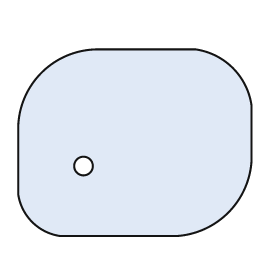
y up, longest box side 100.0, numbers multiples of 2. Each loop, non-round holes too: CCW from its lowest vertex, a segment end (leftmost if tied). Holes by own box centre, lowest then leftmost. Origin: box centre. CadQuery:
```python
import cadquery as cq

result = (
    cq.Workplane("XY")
    .moveTo(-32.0, -40.0)
    .lineTo(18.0, -40.0)
    .threePointArc((40.0, -30.0), (50.0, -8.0))
    .lineTo(50.0, 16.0)
    .threePointArc((42.0, 32.0), (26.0, 40.0))
    .lineTo(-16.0, 40.0)
    .threePointArc((-40.0, 30.0), (-50.0, 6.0))
    .lineTo(-50.0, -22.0)
    .threePointArc((-44.0, -34.0), (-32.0, -40.0))
    .close()
    .moveTo(-22.0, -10.0)
    .circle(4.0)
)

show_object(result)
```